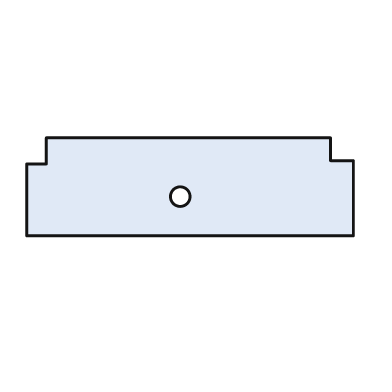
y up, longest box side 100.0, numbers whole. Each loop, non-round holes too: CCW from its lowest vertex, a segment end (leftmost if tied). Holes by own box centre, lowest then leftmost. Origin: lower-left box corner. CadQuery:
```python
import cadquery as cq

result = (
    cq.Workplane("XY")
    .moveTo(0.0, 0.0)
    .lineTo(100.0, 0.0)
    .lineTo(100.0, 23.0)
    .lineTo(93.0, 23.0)
    .lineTo(93.0, 30.0)
    .lineTo(6.0, 30.0)
    .lineTo(6.0, 22.0)
    .lineTo(0.0, 22.0)
    .close()
    .moveTo(47.0, 12.0)
    .circle(3.0)
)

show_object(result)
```